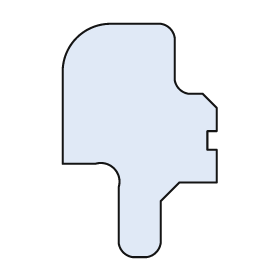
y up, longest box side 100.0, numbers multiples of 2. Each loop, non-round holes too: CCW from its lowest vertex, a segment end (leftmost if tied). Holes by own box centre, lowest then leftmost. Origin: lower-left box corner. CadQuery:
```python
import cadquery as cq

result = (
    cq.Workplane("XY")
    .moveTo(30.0, 0.0)
    .lineTo(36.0, 0.0)
    .threePointArc((40.0, 2.0), (42.0, 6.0))
    .lineTo(42.0, 24.0)
    .lineTo(50.0, 32.0)
    .lineTo(66.0, 32.0)
    .lineTo(66.0, 46.0)
    .lineTo(62.0, 46.0)
    .lineTo(62.0, 54.0)
    .lineTo(66.0, 54.0)
    .lineTo(66.0, 64.0)
    .lineTo(60.0, 70.0)
    .lineTo(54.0, 70.0)
    .threePointArc((50.0, 72.0), (48.0, 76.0))
    .lineTo(48.0, 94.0)
    .threePointArc((46.0, 98.0), (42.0, 100.0))
    .lineTo(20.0, 100.0)
    .threePointArc((6.0, 94.0), (0.0, 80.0))
    .lineTo(0.0, 40.0)
    .lineTo(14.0, 40.0)
    .threePointArc((22.0, 38.0), (24.0, 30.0))
    .lineTo(24.0, 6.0)
    .threePointArc((26.0, 2.0), (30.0, 0.0))
    .close()
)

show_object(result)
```